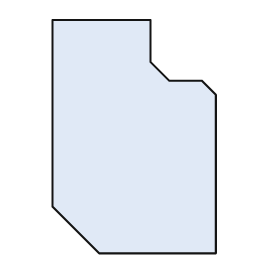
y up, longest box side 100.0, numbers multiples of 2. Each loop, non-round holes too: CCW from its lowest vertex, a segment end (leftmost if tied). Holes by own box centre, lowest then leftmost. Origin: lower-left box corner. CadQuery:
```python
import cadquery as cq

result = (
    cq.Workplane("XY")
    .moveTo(20.0, 0.0)
    .lineTo(70.0, 0.0)
    .lineTo(70.0, 68.0)
    .lineTo(64.0, 74.0)
    .lineTo(50.0, 74.0)
    .lineTo(42.0, 82.0)
    .lineTo(42.0, 100.0)
    .lineTo(0.0, 100.0)
    .lineTo(0.0, 20.0)
    .close()
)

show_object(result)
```